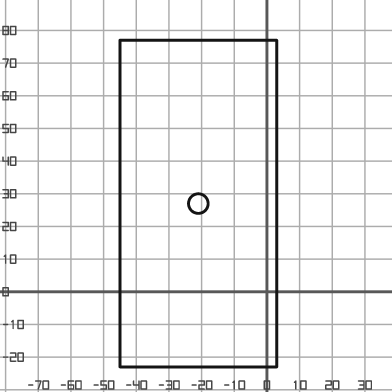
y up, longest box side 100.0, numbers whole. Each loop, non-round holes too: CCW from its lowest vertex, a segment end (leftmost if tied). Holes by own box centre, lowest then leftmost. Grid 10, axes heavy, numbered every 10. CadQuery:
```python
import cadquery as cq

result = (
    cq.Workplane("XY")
    .moveTo(-45.0, -23.0)
    .lineTo(3.0, -23.0)
    .lineTo(3.0, 77.0)
    .lineTo(-45.0, 77.0)
    .close()
    .moveTo(-21.0, 27.0)
    .circle(3.0)
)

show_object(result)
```